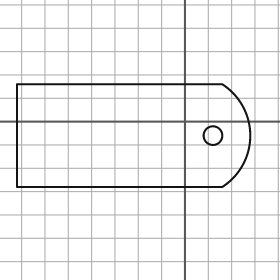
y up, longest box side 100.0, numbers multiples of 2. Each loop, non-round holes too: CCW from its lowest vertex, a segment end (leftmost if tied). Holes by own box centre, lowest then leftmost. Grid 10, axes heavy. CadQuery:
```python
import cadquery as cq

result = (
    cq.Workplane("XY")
    .moveTo(-72.0, -28.0)
    .lineTo(16.0, -28.0)
    .threePointArc((28.0, -6.0), (16.0, 16.0))
    .lineTo(-72.0, 16.0)
    .close()
    .moveTo(12.0, -6.0)
    .circle(4.0)
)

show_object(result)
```